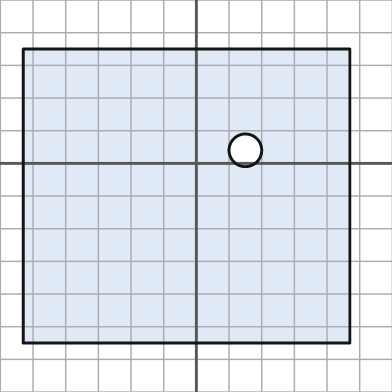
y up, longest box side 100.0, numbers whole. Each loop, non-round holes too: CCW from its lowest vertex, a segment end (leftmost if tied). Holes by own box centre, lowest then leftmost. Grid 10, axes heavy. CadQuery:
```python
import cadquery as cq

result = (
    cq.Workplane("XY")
    .moveTo(-53.0, -55.0)
    .lineTo(47.0, -55.0)
    .lineTo(47.0, 35.0)
    .lineTo(-53.0, 35.0)
    .close()
    .moveTo(15.0, 4.0)
    .circle(5.0)
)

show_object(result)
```